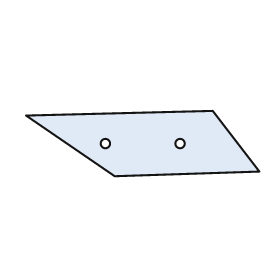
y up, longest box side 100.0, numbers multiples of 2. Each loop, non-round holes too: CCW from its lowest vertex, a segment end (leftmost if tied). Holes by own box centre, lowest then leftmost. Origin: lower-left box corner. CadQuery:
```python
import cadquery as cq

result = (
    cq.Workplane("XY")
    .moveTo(38.0, 0.0)
    .lineTo(100.0, 2.0)
    .lineTo(80.0, 28.0)
    .lineTo(0.0, 26.0)
    .close()
    .moveTo(34.0, 14.0)
    .circle(2.0)
    .moveTo(66.0, 14.0)
    .circle(2.0)
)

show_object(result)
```